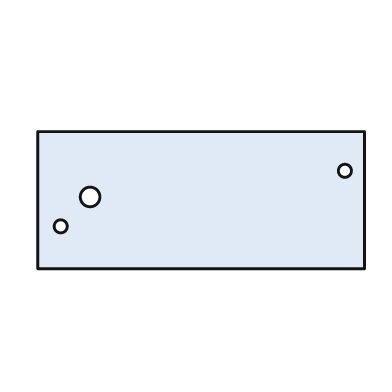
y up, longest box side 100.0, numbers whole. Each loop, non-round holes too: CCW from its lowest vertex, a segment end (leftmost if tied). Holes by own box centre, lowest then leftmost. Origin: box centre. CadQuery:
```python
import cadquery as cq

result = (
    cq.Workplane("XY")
    .moveTo(-50.0, -21.0)
    .lineTo(50.0, -21.0)
    .lineTo(50.0, 21.0)
    .lineTo(-50.0, 21.0)
    .close()
    .moveTo(-43.0, -8.0)
    .circle(2.0)
    .moveTo(-34.0, 1.0)
    .circle(3.0)
    .moveTo(44.0, 9.0)
    .circle(2.0)
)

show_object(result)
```